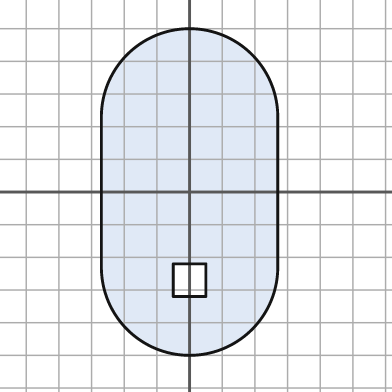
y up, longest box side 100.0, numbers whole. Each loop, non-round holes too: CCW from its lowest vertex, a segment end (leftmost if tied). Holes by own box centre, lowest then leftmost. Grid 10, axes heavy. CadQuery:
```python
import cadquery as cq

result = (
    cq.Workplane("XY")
    .moveTo(-27.0, -23.0)
    .threePointArc((0.0, -50.0), (27.0, -23.0))
    .lineTo(27.0, 23.0)
    .threePointArc((0.0, 50.0), (-27.0, 23.0))
    .close()
    .moveTo(-5.0, -32.0)
    .lineTo(5.0, -32.0)
    .lineTo(5.0, -22.0)
    .lineTo(-5.0, -22.0)
    .close()
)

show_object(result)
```